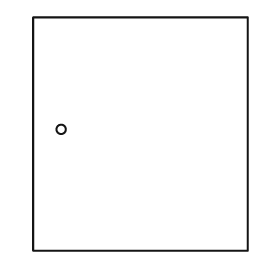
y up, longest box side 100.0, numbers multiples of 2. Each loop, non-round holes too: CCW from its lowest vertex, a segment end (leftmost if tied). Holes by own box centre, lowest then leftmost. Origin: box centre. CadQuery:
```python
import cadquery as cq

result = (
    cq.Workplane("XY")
    .moveTo(-46.0, -50.0)
    .lineTo(46.0, -50.0)
    .lineTo(46.0, 50.0)
    .lineTo(-46.0, 50.0)
    .close()
    .moveTo(-34.0, 2.0)
    .circle(2.0)
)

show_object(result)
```